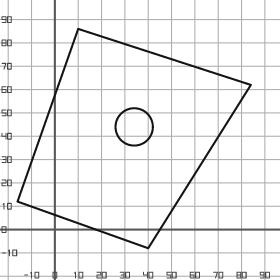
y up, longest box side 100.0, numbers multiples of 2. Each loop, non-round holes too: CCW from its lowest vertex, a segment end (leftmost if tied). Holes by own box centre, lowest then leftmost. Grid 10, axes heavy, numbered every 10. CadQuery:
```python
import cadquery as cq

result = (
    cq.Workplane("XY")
    .moveTo(40.0, -8.0)
    .lineTo(84.0, 62.0)
    .lineTo(10.0, 86.0)
    .lineTo(-16.0, 12.0)
    .close()
    .moveTo(34.0, 44.0)
    .circle(8.0)
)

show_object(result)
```